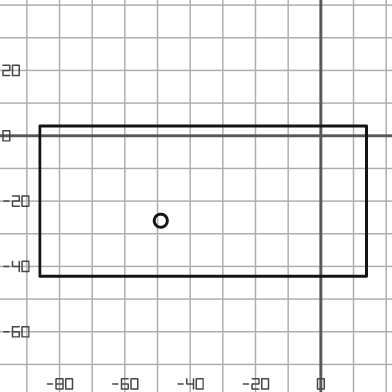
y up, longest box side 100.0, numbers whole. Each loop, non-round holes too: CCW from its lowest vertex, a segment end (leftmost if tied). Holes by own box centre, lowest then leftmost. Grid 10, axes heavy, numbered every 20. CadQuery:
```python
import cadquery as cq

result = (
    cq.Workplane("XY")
    .moveTo(-86.0, -43.0)
    .lineTo(14.0, -43.0)
    .lineTo(14.0, 3.0)
    .lineTo(-86.0, 3.0)
    .close()
    .moveTo(-49.0, -26.0)
    .circle(2.0)
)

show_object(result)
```